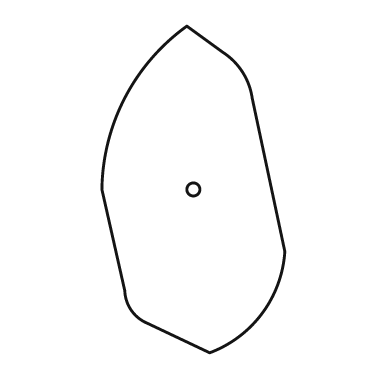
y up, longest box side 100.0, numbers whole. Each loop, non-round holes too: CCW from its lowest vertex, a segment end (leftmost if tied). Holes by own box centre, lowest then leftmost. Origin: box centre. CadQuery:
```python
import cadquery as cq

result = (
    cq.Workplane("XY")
    .moveTo(5.0, -50.0)
    .threePointArc((21.0, -38.0), (28.0, -19.0))
    .lineTo(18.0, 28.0)
    .threePointArc((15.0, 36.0), (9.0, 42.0))
    .lineTo(-2.0, 50.0)
    .threePointArc((-21.0, 28.0), (-28.0, 0.0))
    .lineTo(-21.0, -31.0)
    .threePointArc((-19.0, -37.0), (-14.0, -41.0))
    .close()
    .moveTo(0.0, 0.0)
    .circle(2.0)
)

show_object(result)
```